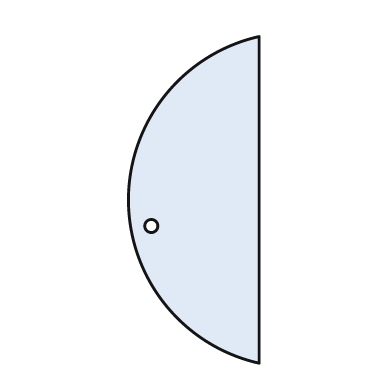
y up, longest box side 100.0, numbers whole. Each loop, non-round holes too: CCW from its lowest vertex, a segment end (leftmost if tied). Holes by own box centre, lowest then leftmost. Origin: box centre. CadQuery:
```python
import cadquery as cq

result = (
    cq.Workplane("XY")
    .moveTo(20.0, -50.0)
    .lineTo(20.0, 50.0)
    .threePointArc((-20.0, 0.0), (20.0, -50.0))
    .close()
    .moveTo(-13.0, -8.0)
    .circle(2.0)
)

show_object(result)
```